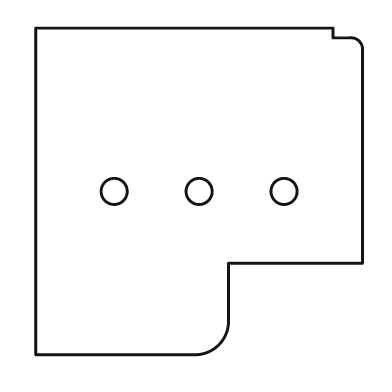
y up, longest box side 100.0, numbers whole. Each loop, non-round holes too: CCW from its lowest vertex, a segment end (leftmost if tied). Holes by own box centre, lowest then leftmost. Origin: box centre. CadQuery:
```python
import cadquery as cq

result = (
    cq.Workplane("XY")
    .moveTo(-50.0, -50.0)
    .lineTo(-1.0, -50.0)
    .threePointArc((6.0, -47.0), (9.0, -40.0))
    .lineTo(9.0, -22.0)
    .lineTo(50.0, -22.0)
    .lineTo(50.0, 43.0)
    .threePointArc((49.0, 46.0), (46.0, 47.0))
    .lineTo(41.0, 47.0)
    .lineTo(41.0, 50.0)
    .lineTo(-50.0, 50.0)
    .close()
    .moveTo(-26.0, 0.0)
    .circle(4.0)
    .moveTo(0.0, 0.0)
    .circle(4.0)
    .moveTo(26.0, 0.0)
    .circle(4.0)
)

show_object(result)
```